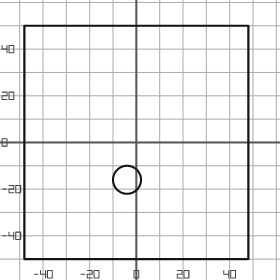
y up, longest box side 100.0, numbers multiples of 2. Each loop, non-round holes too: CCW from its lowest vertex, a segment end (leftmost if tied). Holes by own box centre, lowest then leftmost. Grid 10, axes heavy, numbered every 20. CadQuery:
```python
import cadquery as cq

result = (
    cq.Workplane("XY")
    .moveTo(-48.0, -50.0)
    .lineTo(48.0, -50.0)
    .lineTo(48.0, 50.0)
    .lineTo(-48.0, 50.0)
    .close()
    .moveTo(-4.0, -16.0)
    .circle(6.0)
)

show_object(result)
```